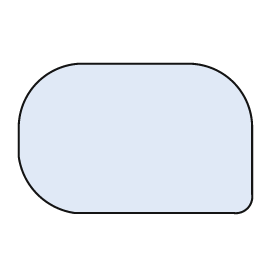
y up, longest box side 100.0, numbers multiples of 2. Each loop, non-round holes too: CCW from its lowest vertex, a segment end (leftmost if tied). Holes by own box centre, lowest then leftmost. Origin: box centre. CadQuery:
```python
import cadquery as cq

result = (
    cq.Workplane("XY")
    .moveTo(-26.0, -32.0)
    .lineTo(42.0, -32.0)
    .threePointArc((48.0, -30.0), (50.0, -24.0))
    .lineTo(50.0, 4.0)
    .threePointArc((42.0, 24.0), (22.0, 32.0))
    .lineTo(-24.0, 32.0)
    .threePointArc((-42.0, 24.0), (-50.0, 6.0))
    .lineTo(-50.0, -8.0)
    .threePointArc((-42.0, -24.0), (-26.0, -32.0))
    .close()
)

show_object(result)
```